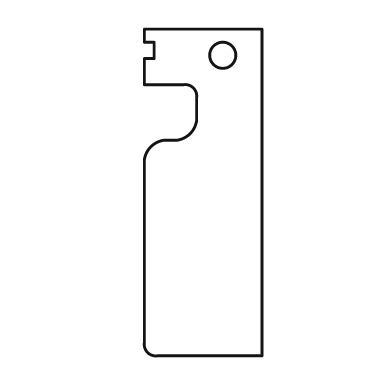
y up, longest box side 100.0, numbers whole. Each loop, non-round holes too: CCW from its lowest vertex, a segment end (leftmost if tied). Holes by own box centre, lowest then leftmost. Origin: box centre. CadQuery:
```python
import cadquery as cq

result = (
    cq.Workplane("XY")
    .moveTo(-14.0, -50.0)
    .lineTo(18.0, -50.0)
    .lineTo(18.0, 50.0)
    .lineTo(-18.0, 50.0)
    .lineTo(-18.0, 46.0)
    .lineTo(-15.0, 46.0)
    .lineTo(-15.0, 41.0)
    .lineTo(-18.0, 41.0)
    .lineTo(-18.0, 33.0)
    .lineTo(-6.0, 33.0)
    .threePointArc((-3.0, 32.0), (-2.0, 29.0))
    .lineTo(-2.0, 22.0)
    .threePointArc((-4.0, 18.0), (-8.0, 16.0))
    .lineTo(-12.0, 16.0)
    .threePointArc((-16.0, 14.0), (-18.0, 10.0))
    .lineTo(-18.0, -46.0)
    .threePointArc((-17.0, -49.0), (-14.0, -50.0))
    .close()
    .moveTo(6.0, 42.0)
    .circle(4.0)
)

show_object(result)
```